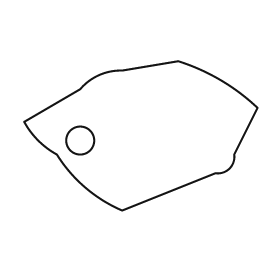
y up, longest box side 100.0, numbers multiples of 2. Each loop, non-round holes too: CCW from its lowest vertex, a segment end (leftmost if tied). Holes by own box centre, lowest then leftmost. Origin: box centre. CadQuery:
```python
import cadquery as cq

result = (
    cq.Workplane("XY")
    .moveTo(-8.0, -32.0)
    .lineTo(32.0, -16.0)
    .threePointArc((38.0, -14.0), (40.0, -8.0))
    .lineTo(50.0, 12.0)
    .threePointArc((34.0, 24.0), (16.0, 32.0))
    .lineTo(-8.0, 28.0)
    .threePointArc((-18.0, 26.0), (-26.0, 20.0))
    .lineTo(-50.0, 6.0)
    .threePointArc((-44.0, -2.0), (-36.0, -8.0))
    .threePointArc((-24.0, -22.0), (-8.0, -32.0))
    .close()
    .moveTo(-26.0, -2.0)
    .circle(6.0)
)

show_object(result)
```